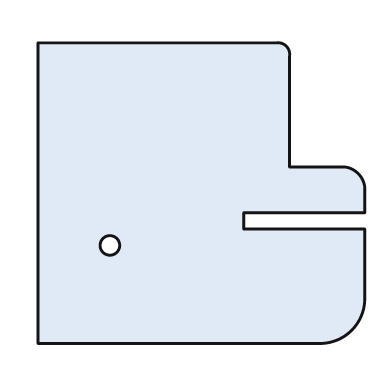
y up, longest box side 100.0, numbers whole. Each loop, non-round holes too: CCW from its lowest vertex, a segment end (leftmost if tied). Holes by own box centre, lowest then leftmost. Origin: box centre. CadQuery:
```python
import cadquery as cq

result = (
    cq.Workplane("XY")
    .moveTo(-50.0, -46.0)
    .lineTo(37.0, -46.0)
    .threePointArc((46.0, -42.0), (50.0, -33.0))
    .lineTo(50.0, -11.0)
    .lineTo(13.0, -11.0)
    .lineTo(13.0, -6.0)
    .lineTo(50.0, -6.0)
    .lineTo(50.0, 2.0)
    .threePointArc((48.0, 6.0), (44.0, 8.0))
    .lineTo(27.0, 8.0)
    .lineTo(27.0, 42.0)
    .threePointArc((26.0, 45.0), (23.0, 46.0))
    .lineTo(-50.0, 46.0)
    .close()
    .moveTo(-28.0, -16.0)
    .circle(3.0)
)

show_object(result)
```